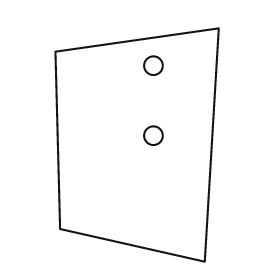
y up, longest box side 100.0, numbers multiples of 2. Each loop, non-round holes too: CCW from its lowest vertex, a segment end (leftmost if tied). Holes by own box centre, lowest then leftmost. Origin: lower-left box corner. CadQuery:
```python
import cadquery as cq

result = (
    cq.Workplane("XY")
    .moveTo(64.0, 0.0)
    .lineTo(70.0, 100.0)
    .lineTo(0.0, 90.0)
    .lineTo(2.0, 14.0)
    .close()
    .moveTo(42.0, 54.0)
    .circle(4.0)
    .moveTo(42.0, 84.0)
    .circle(4.0)
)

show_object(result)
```